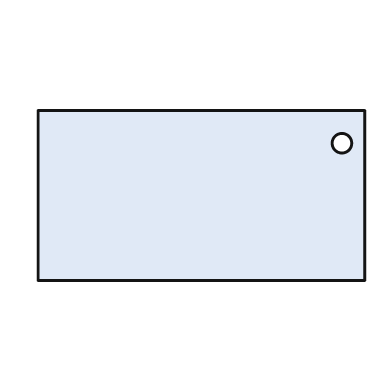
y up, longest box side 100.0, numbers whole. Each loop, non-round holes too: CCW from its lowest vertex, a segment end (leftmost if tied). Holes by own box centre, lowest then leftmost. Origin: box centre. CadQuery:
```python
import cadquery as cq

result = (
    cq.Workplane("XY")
    .moveTo(-50.0, -26.0)
    .lineTo(50.0, -26.0)
    .lineTo(50.0, 26.0)
    .lineTo(-50.0, 26.0)
    .close()
    .moveTo(43.0, 16.0)
    .circle(3.0)
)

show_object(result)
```